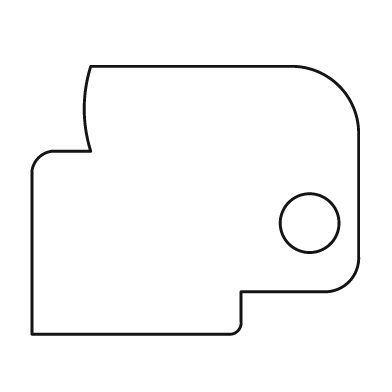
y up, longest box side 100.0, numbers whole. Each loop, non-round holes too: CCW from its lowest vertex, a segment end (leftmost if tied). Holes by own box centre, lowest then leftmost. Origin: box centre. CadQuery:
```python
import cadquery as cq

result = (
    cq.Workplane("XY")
    .moveTo(-50.0, -41.0)
    .lineTo(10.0, -41.0)
    .threePointArc((13.0, -40.0), (14.0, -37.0))
    .lineTo(14.0, -28.0)
    .lineTo(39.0, -28.0)
    .threePointArc((47.0, -25.0), (50.0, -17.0))
    .lineTo(50.0, 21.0)
    .threePointArc((44.0, 35.0), (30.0, 41.0))
    .lineTo(-32.0, 41.0)
    .threePointArc((-34.0, 28.0), (-32.0, 15.0))
    .lineTo(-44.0, 15.0)
    .threePointArc((-48.0, 13.0), (-50.0, 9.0))
    .close()
    .moveTo(35.0, -7.0)
    .circle(9.0)
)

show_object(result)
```